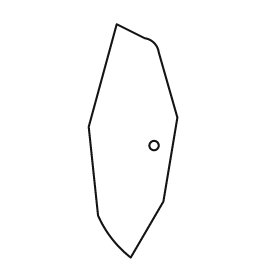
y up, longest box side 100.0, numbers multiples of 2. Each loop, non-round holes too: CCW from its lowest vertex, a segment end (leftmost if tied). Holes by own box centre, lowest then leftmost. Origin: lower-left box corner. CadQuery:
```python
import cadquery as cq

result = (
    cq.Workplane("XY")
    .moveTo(18.0, 0.0)
    .lineTo(32.0, 24.0)
    .lineTo(38.0, 60.0)
    .lineTo(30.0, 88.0)
    .threePointArc((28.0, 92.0), (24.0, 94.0))
    .lineTo(12.0, 100.0)
    .lineTo(0.0, 56.0)
    .lineTo(4.0, 18.0)
    .threePointArc((10.0, 8.0), (18.0, 0.0))
    .close()
    .moveTo(28.0, 48.0)
    .circle(2.0)
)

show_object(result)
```